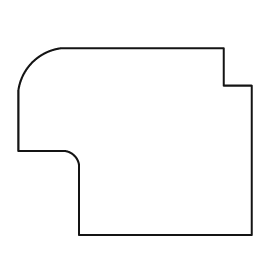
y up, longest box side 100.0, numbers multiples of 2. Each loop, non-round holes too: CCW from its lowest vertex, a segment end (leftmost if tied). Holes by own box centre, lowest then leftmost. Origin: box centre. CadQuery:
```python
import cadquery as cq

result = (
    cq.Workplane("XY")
    .moveTo(-24.0, -40.0)
    .lineTo(50.0, -40.0)
    .lineTo(50.0, 24.0)
    .lineTo(38.0, 24.0)
    .lineTo(38.0, 40.0)
    .lineTo(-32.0, 40.0)
    .threePointArc((-44.0, 34.0), (-50.0, 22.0))
    .lineTo(-50.0, -4.0)
    .lineTo(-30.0, -4.0)
    .threePointArc((-26.0, -6.0), (-24.0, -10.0))
    .close()
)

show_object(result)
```